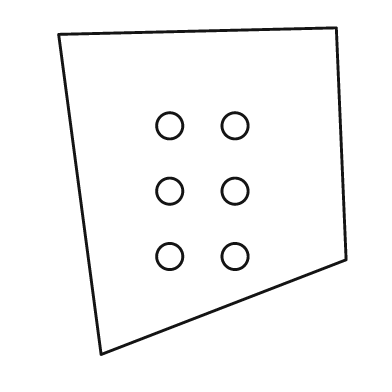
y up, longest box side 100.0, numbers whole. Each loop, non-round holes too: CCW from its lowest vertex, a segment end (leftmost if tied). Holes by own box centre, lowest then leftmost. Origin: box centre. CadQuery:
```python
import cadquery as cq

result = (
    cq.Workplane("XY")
    .moveTo(-31.0, -50.0)
    .lineTo(44.0, -21.0)
    .lineTo(41.0, 50.0)
    .lineTo(-44.0, 48.0)
    .close()
    .moveTo(-10.0, -20.0)
    .circle(4.0)
    .moveTo(10.0, -20.0)
    .circle(4.0)
    .moveTo(-10.0, 0.0)
    .circle(4.0)
    .moveTo(10.0, 0.0)
    .circle(4.0)
    .moveTo(-10.0, 20.0)
    .circle(4.0)
    .moveTo(10.0, 20.0)
    .circle(4.0)
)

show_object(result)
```